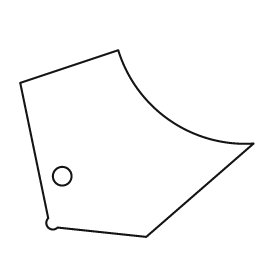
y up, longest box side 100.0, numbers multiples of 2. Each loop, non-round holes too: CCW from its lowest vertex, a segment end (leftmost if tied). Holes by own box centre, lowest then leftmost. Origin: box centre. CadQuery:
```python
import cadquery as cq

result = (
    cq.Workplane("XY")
    .moveTo(4.0, -40.0)
    .lineTo(50.0, 0.0)
    .threePointArc((14.0, 10.0), (-8.0, 40.0))
    .lineTo(-50.0, 26.0)
    .lineTo(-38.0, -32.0)
    .threePointArc((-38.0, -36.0), (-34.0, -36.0))
    .close()
    .moveTo(-32.0, -14.0)
    .circle(4.0)
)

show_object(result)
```